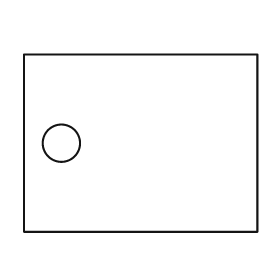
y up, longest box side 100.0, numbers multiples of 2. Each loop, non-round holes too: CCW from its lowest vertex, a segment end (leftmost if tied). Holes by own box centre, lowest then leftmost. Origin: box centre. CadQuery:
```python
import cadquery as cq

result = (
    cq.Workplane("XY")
    .moveTo(-50.0, -38.0)
    .lineTo(50.0, -38.0)
    .lineTo(50.0, 38.0)
    .lineTo(-50.0, 38.0)
    .close()
    .moveTo(-34.0, 0.0)
    .circle(8.0)
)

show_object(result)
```